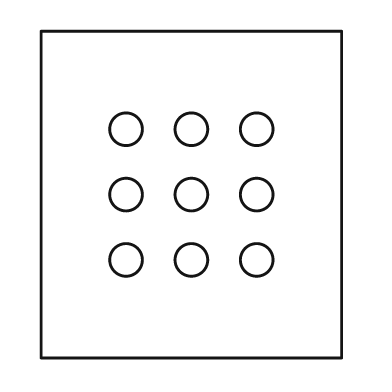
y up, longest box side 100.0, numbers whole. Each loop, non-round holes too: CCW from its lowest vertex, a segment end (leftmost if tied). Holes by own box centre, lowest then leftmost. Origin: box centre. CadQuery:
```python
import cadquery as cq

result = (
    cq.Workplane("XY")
    .moveTo(-46.0, -50.0)
    .lineTo(46.0, -50.0)
    .lineTo(46.0, 50.0)
    .lineTo(-46.0, 50.0)
    .close()
    .moveTo(-20.0, -20.0)
    .circle(5.0)
    .moveTo(0.0, -20.0)
    .circle(5.0)
    .moveTo(20.0, -20.0)
    .circle(5.0)
    .moveTo(-20.0, 0.0)
    .circle(5.0)
    .moveTo(0.0, 0.0)
    .circle(5.0)
    .moveTo(20.0, 0.0)
    .circle(5.0)
    .moveTo(-20.0, 20.0)
    .circle(5.0)
    .moveTo(0.0, 20.0)
    .circle(5.0)
    .moveTo(20.0, 20.0)
    .circle(5.0)
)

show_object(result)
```